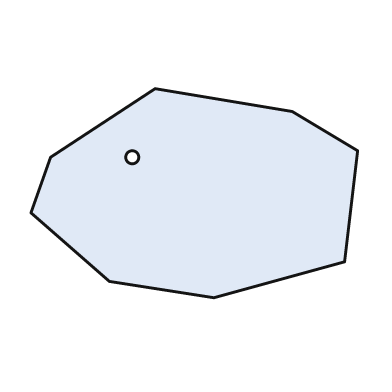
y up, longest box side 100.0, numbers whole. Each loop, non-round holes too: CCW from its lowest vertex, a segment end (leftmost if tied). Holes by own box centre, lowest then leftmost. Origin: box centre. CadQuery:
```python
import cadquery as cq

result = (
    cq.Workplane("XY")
    .moveTo(6.0, -32.0)
    .lineTo(46.0, -21.0)
    .lineTo(50.0, 13.0)
    .lineTo(30.0, 25.0)
    .lineTo(-12.0, 32.0)
    .lineTo(-44.0, 11.0)
    .lineTo(-50.0, -6.0)
    .lineTo(-26.0, -27.0)
    .close()
    .moveTo(-19.0, 11.0)
    .circle(2.0)
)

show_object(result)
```